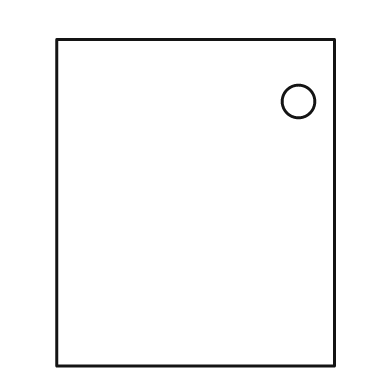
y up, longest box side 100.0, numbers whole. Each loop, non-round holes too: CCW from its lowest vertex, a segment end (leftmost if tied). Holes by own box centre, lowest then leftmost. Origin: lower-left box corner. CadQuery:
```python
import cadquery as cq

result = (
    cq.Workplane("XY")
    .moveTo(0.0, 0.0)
    .lineTo(85.0, 0.0)
    .lineTo(85.0, 100.0)
    .lineTo(0.0, 100.0)
    .close()
    .moveTo(74.0, 81.0)
    .circle(5.0)
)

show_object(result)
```